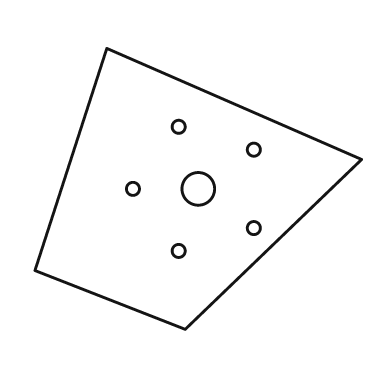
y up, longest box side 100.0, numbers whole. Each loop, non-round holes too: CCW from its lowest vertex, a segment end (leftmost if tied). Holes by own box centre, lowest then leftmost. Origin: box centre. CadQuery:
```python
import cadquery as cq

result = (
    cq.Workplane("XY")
    .moveTo(-4.0, -43.0)
    .lineTo(50.0, 9.0)
    .lineTo(-28.0, 43.0)
    .lineTo(-50.0, -25.0)
    .close()
    .moveTo(-6.0, -19.0)
    .circle(2.0)
    .moveTo(17.0, -12.0)
    .circle(2.0)
    .moveTo(-20.0, 0.0)
    .circle(2.0)
    .moveTo(0.0, 0.0)
    .circle(5.0)
    .moveTo(17.0, 12.0)
    .circle(2.0)
    .moveTo(-6.0, 19.0)
    .circle(2.0)
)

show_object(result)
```